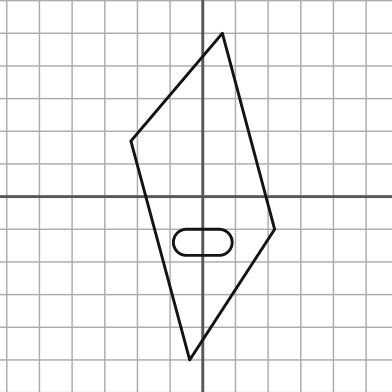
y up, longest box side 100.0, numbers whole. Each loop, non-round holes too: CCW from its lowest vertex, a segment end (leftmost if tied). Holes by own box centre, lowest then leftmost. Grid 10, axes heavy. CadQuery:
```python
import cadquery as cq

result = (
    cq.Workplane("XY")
    .moveTo(-4.0, -50.0)
    .lineTo(22.0, -10.0)
    .lineTo(6.0, 50.0)
    .lineTo(-22.0, 17.0)
    .close()
    .moveTo(-5.0, -18.0)
    .lineTo(5.0, -18.0)
    .threePointArc((9.0, -14.0), (5.0, -10.0))
    .lineTo(-5.0, -10.0)
    .threePointArc((-9.0, -14.0), (-5.0, -18.0))
    .close()
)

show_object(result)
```